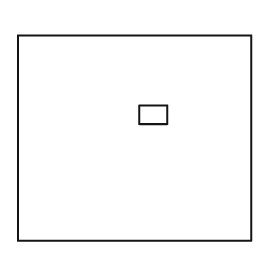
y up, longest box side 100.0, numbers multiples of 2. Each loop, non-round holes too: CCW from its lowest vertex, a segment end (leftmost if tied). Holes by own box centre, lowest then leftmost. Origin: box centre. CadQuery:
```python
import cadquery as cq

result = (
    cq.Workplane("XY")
    .moveTo(-50.0, -44.0)
    .lineTo(50.0, -44.0)
    .lineTo(50.0, 44.0)
    .lineTo(-50.0, 44.0)
    .close()
    .moveTo(2.0, 6.0)
    .lineTo(14.0, 6.0)
    .lineTo(14.0, 14.0)
    .lineTo(2.0, 14.0)
    .close()
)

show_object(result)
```